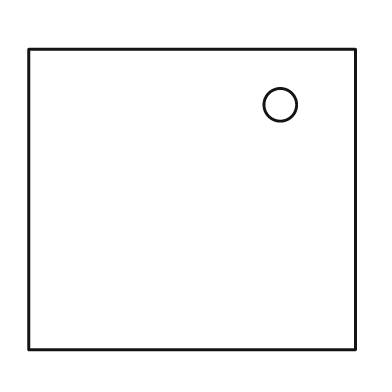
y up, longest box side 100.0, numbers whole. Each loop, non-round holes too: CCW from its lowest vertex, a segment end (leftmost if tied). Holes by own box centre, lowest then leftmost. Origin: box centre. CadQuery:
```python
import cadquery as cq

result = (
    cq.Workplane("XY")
    .moveTo(-50.0, -46.0)
    .lineTo(50.0, -46.0)
    .lineTo(50.0, 46.0)
    .lineTo(-50.0, 46.0)
    .close()
    .moveTo(27.0, 29.0)
    .circle(5.0)
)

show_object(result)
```